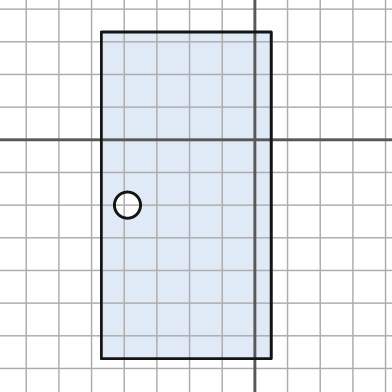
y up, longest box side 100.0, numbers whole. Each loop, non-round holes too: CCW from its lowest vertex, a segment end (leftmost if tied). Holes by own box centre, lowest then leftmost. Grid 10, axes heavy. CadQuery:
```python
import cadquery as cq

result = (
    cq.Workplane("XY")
    .moveTo(-47.0, -67.0)
    .lineTo(5.0, -67.0)
    .lineTo(5.0, 33.0)
    .lineTo(-47.0, 33.0)
    .close()
    .moveTo(-39.0, -20.0)
    .circle(4.0)
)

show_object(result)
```